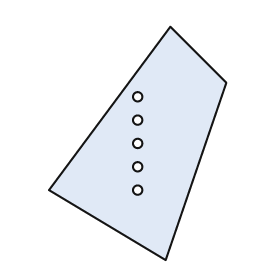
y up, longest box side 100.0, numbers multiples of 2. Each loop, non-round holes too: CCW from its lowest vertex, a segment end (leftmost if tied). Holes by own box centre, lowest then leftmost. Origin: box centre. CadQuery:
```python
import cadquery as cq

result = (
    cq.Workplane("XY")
    .moveTo(12.0, -50.0)
    .lineTo(38.0, 26.0)
    .lineTo(14.0, 50.0)
    .lineTo(-38.0, -20.0)
    .close()
    .moveTo(0.0, -20.0)
    .circle(2.0)
    .moveTo(0.0, -10.0)
    .circle(2.0)
    .moveTo(0.0, 0.0)
    .circle(2.0)
    .moveTo(0.0, 10.0)
    .circle(2.0)
    .moveTo(0.0, 20.0)
    .circle(2.0)
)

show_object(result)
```